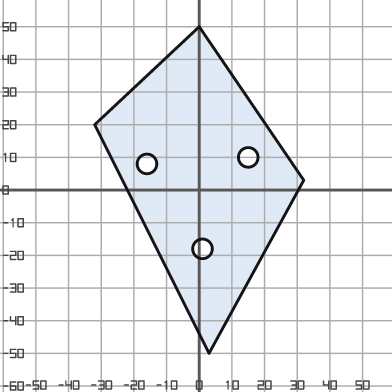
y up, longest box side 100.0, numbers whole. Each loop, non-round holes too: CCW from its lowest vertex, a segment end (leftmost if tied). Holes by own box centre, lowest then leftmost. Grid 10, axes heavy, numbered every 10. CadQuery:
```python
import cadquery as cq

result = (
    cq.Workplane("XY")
    .moveTo(3.0, -50.0)
    .lineTo(32.0, 3.0)
    .lineTo(0.0, 50.0)
    .lineTo(-32.0, 20.0)
    .close()
    .moveTo(1.0, -18.0)
    .circle(3.0)
    .moveTo(-16.0, 8.0)
    .circle(3.0)
    .moveTo(15.0, 10.0)
    .circle(3.0)
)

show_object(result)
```